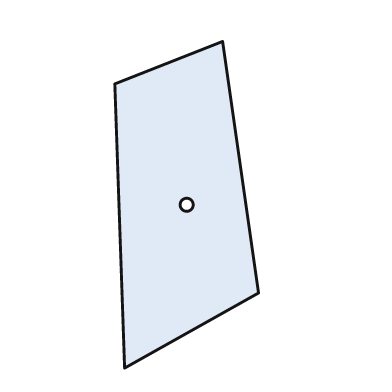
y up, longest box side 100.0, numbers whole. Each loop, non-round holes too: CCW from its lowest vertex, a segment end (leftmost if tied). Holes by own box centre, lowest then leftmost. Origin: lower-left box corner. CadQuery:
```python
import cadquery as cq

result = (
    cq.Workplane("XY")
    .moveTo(3.0, 0.0)
    .lineTo(44.0, 23.0)
    .lineTo(33.0, 100.0)
    .lineTo(0.0, 87.0)
    .close()
    .moveTo(22.0, 50.0)
    .circle(2.0)
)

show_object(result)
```